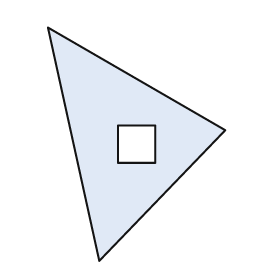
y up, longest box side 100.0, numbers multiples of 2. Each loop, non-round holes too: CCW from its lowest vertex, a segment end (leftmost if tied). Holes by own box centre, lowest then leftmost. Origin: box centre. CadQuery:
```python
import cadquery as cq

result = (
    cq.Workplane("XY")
    .moveTo(-16.0, -50.0)
    .lineTo(38.0, 6.0)
    .lineTo(-38.0, 50.0)
    .close()
    .moveTo(-8.0, -8.0)
    .lineTo(8.0, -8.0)
    .lineTo(8.0, 8.0)
    .lineTo(-8.0, 8.0)
    .close()
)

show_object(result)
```